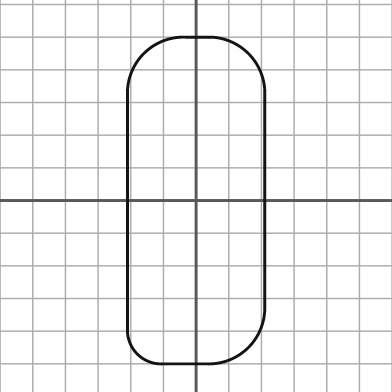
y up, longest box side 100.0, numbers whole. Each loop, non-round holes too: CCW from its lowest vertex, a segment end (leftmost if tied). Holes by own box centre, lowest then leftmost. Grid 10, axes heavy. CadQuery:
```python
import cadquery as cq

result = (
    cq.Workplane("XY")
    .moveTo(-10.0, -50.0)
    .lineTo(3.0, -50.0)
    .threePointArc((16.0, -45.0), (21.0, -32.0))
    .lineTo(21.0, 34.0)
    .threePointArc((16.0, 45.0), (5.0, 50.0))
    .lineTo(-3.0, 50.0)
    .threePointArc((-16.0, 45.0), (-21.0, 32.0))
    .lineTo(-21.0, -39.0)
    .threePointArc((-18.0, -47.0), (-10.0, -50.0))
    .close()
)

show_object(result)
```